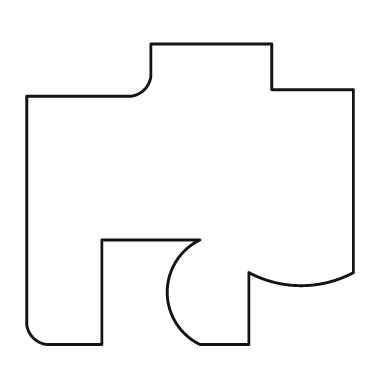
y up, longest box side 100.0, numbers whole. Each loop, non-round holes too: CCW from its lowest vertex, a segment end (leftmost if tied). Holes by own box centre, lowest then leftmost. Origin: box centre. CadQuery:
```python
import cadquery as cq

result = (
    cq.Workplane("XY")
    .moveTo(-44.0, -46.0)
    .lineTo(-27.0, -46.0)
    .lineTo(-27.0, -14.0)
    .lineTo(3.0, -14.0)
    .threePointArc((-7.0, -30.0), (3.0, -46.0))
    .lineTo(18.0, -46.0)
    .lineTo(18.0, -24.0)
    .threePointArc((34.0, -28.0), (50.0, -24.0))
    .lineTo(50.0, 32.0)
    .lineTo(25.0, 32.0)
    .lineTo(25.0, 46.0)
    .lineTo(-12.0, 46.0)
    .lineTo(-12.0, 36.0)
    .threePointArc((-14.0, 32.0), (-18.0, 30.0))
    .lineTo(-50.0, 30.0)
    .lineTo(-50.0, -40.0)
    .threePointArc((-48.0, -44.0), (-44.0, -46.0))
    .close()
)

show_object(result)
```